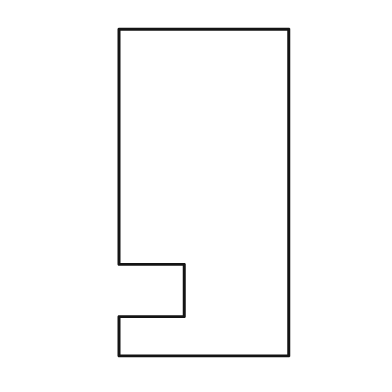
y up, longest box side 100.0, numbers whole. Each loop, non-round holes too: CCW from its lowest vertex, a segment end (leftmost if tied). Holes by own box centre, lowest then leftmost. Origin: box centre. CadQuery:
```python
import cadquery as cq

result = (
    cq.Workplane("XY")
    .moveTo(-26.0, -50.0)
    .lineTo(26.0, -50.0)
    .lineTo(26.0, 50.0)
    .lineTo(-26.0, 50.0)
    .lineTo(-26.0, -22.0)
    .lineTo(-6.0, -22.0)
    .lineTo(-6.0, -38.0)
    .lineTo(-26.0, -38.0)
    .close()
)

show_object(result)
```